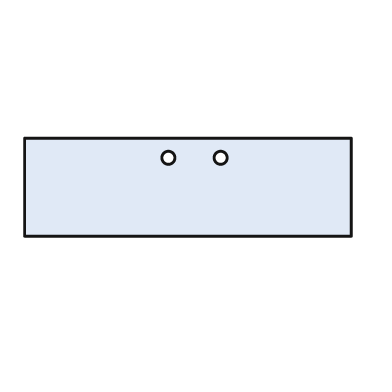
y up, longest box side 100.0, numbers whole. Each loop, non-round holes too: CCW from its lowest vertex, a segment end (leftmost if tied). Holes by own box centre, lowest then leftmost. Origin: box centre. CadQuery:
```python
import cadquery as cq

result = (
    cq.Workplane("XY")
    .moveTo(-50.0, -15.0)
    .lineTo(50.0, -15.0)
    .lineTo(50.0, 15.0)
    .lineTo(-50.0, 15.0)
    .close()
    .moveTo(-6.0, 9.0)
    .circle(2.0)
    .moveTo(10.0, 9.0)
    .circle(2.0)
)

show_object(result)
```